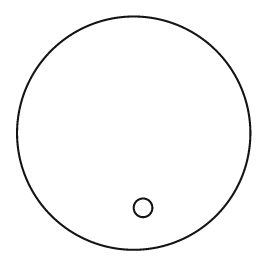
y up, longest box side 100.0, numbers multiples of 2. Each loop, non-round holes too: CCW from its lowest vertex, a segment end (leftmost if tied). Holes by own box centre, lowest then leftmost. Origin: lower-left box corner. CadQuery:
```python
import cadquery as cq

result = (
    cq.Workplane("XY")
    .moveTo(50.0, 50.0)
    .circle(50.0)
    .moveTo(54.0, 18.0)
    .circle(4.0)
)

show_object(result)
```